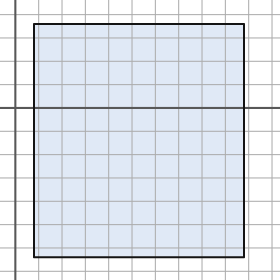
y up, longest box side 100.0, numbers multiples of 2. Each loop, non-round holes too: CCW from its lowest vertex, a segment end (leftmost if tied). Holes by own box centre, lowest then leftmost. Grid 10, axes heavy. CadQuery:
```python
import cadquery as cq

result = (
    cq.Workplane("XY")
    .moveTo(8.0, -64.0)
    .lineTo(98.0, -64.0)
    .lineTo(98.0, 36.0)
    .lineTo(8.0, 36.0)
    .close()
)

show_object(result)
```